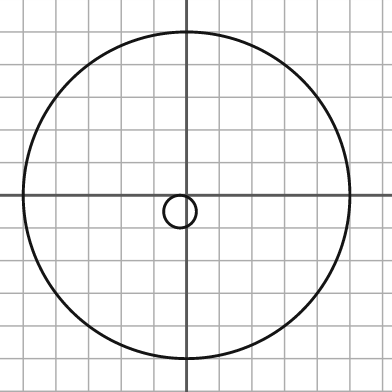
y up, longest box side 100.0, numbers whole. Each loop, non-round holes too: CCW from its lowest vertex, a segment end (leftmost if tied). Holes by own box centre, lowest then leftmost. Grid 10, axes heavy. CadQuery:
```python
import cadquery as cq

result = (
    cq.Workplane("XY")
    .moveTo(0.0, 0.0)
    .circle(50.0)
    .moveTo(-2.0, -5.0)
    .circle(5.0)
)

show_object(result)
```